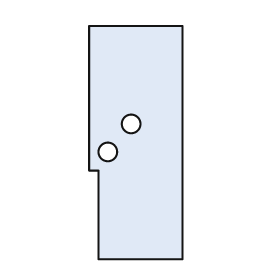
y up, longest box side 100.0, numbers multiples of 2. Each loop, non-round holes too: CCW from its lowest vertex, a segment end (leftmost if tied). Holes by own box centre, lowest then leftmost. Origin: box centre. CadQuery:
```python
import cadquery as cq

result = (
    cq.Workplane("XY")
    .moveTo(-16.0, -50.0)
    .lineTo(20.0, -50.0)
    .lineTo(20.0, 50.0)
    .lineTo(-20.0, 50.0)
    .lineTo(-20.0, -12.0)
    .lineTo(-16.0, -12.0)
    .close()
    .moveTo(-12.0, -4.0)
    .circle(4.0)
    .moveTo(-2.0, 8.0)
    .circle(4.0)
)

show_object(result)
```